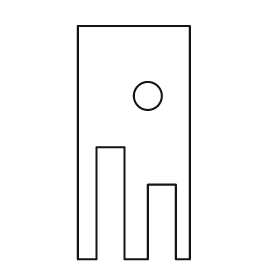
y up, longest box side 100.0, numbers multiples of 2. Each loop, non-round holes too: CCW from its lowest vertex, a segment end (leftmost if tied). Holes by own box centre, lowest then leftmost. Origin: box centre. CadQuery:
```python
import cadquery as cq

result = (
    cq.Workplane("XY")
    .moveTo(-24.0, -50.0)
    .lineTo(-16.0, -50.0)
    .lineTo(-16.0, -2.0)
    .lineTo(-4.0, -2.0)
    .lineTo(-4.0, -50.0)
    .lineTo(6.0, -50.0)
    .lineTo(6.0, -18.0)
    .lineTo(18.0, -18.0)
    .lineTo(18.0, -50.0)
    .lineTo(24.0, -50.0)
    .lineTo(24.0, 50.0)
    .lineTo(-24.0, 50.0)
    .close()
    .moveTo(6.0, 20.0)
    .circle(6.0)
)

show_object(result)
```